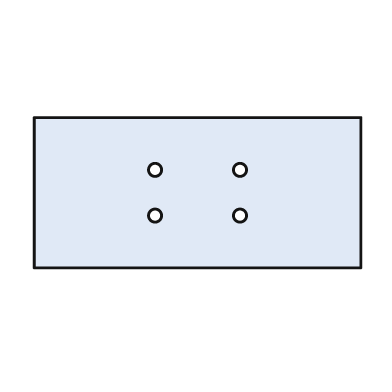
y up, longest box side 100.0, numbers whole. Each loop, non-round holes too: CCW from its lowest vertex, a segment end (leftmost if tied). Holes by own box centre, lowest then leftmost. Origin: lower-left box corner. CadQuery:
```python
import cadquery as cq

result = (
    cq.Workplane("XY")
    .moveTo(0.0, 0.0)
    .lineTo(100.0, 0.0)
    .lineTo(100.0, 46.0)
    .lineTo(0.0, 46.0)
    .close()
    .moveTo(37.0, 16.0)
    .circle(2.0)
    .moveTo(63.0, 16.0)
    .circle(2.0)
    .moveTo(37.0, 30.0)
    .circle(2.0)
    .moveTo(63.0, 30.0)
    .circle(2.0)
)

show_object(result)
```